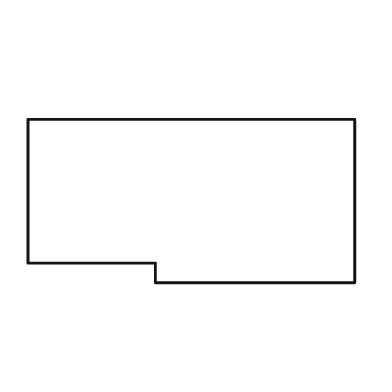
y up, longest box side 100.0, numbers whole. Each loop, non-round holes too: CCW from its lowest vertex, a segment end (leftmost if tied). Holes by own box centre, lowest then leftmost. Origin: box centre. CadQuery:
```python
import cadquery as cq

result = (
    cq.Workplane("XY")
    .moveTo(-11.0, -25.0)
    .lineTo(50.0, -25.0)
    .lineTo(50.0, 25.0)
    .lineTo(-50.0, 25.0)
    .lineTo(-50.0, -19.0)
    .lineTo(-11.0, -19.0)
    .close()
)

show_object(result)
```